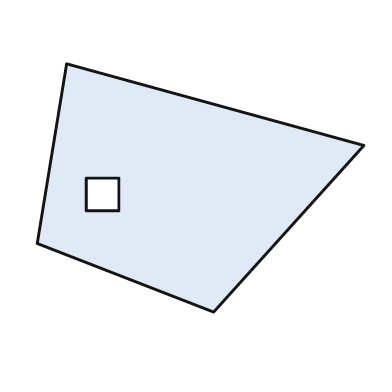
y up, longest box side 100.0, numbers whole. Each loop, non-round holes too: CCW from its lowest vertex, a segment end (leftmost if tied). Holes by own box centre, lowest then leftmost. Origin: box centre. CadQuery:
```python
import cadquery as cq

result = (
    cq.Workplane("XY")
    .moveTo(4.0, -38.0)
    .lineTo(50.0, 13.0)
    .lineTo(-41.0, 38.0)
    .lineTo(-50.0, -17.0)
    .close()
    .moveTo(-35.0, -7.0)
    .lineTo(-25.0, -7.0)
    .lineTo(-25.0, 3.0)
    .lineTo(-35.0, 3.0)
    .close()
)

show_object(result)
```